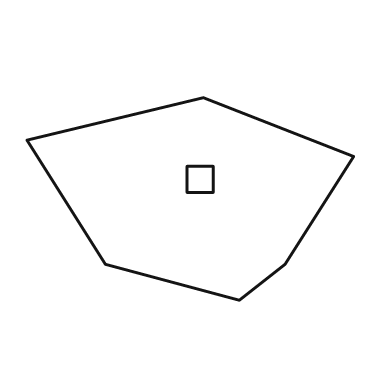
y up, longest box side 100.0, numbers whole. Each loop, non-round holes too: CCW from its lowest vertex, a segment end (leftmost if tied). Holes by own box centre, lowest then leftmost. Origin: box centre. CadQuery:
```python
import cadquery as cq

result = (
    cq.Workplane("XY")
    .moveTo(15.0, -31.0)
    .lineTo(29.0, -20.0)
    .lineTo(50.0, 13.0)
    .lineTo(4.0, 31.0)
    .lineTo(-50.0, 18.0)
    .lineTo(-26.0, -20.0)
    .close()
    .moveTo(-1.0, 2.0)
    .lineTo(7.0, 2.0)
    .lineTo(7.0, 10.0)
    .lineTo(-1.0, 10.0)
    .close()
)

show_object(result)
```